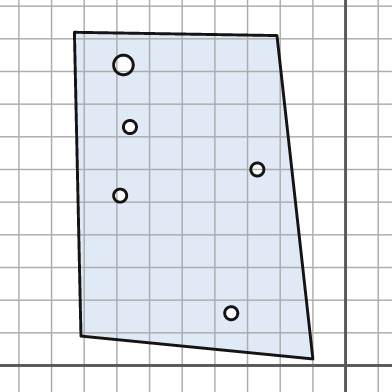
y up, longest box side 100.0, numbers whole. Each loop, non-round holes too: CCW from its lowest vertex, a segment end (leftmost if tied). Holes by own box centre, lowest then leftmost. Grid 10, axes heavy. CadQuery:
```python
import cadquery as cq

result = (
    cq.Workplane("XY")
    .moveTo(-10.0, 2.0)
    .lineTo(-21.0, 101.0)
    .lineTo(-83.0, 102.0)
    .lineTo(-81.0, 9.0)
    .close()
    .moveTo(-35.0, 16.0)
    .circle(2.0)
    .moveTo(-69.0, 52.0)
    .circle(2.0)
    .moveTo(-27.0, 60.0)
    .circle(2.0)
    .moveTo(-66.0, 73.0)
    .circle(2.0)
    .moveTo(-68.0, 92.0)
    .circle(3.0)
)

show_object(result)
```